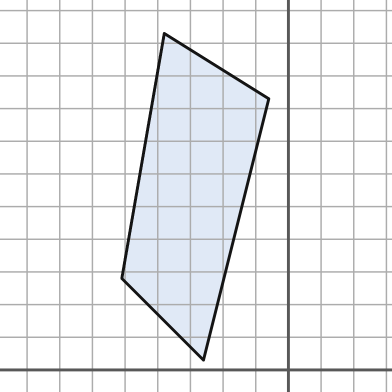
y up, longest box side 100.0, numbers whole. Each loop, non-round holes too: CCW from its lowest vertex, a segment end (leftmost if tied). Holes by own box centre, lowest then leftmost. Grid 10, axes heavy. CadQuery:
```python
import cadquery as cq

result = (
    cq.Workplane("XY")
    .moveTo(-26.0, 3.0)
    .lineTo(-6.0, 83.0)
    .lineTo(-38.0, 103.0)
    .lineTo(-51.0, 28.0)
    .close()
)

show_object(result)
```